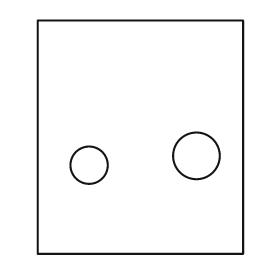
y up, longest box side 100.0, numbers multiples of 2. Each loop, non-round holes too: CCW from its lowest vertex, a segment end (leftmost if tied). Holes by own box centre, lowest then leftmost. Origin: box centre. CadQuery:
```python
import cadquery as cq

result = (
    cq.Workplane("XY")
    .moveTo(-44.0, -50.0)
    .lineTo(44.0, -50.0)
    .lineTo(44.0, 50.0)
    .lineTo(-44.0, 50.0)
    .close()
    .moveTo(-22.0, -12.0)
    .circle(8.0)
    .moveTo(24.0, -8.0)
    .circle(10.0)
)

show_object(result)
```